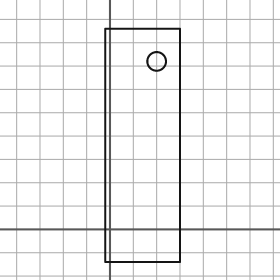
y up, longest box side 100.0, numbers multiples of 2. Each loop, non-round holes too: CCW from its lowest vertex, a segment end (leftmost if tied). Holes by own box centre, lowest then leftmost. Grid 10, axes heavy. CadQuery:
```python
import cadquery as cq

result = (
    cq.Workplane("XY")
    .moveTo(-2.0, -14.0)
    .lineTo(30.0, -14.0)
    .lineTo(30.0, 86.0)
    .lineTo(-2.0, 86.0)
    .close()
    .moveTo(20.0, 72.0)
    .circle(4.0)
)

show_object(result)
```